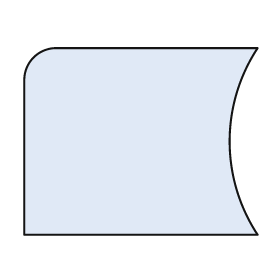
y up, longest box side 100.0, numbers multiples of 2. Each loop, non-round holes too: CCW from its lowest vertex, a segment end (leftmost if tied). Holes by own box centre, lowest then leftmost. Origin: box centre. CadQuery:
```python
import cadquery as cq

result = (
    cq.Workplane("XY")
    .moveTo(-50.0, -40.0)
    .lineTo(50.0, -40.0)
    .threePointArc((38.0, 0.0), (50.0, 40.0))
    .lineTo(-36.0, 40.0)
    .threePointArc((-46.0, 36.0), (-50.0, 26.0))
    .close()
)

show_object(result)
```